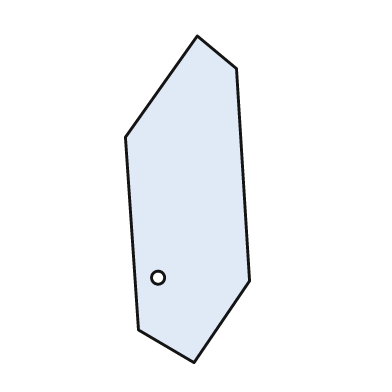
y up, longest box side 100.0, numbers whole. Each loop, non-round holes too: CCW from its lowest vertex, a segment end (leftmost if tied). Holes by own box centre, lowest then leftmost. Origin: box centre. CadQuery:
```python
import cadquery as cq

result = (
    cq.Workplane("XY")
    .moveTo(2.0, -50.0)
    .lineTo(19.0, -25.0)
    .lineTo(15.0, 40.0)
    .lineTo(3.0, 50.0)
    .lineTo(-19.0, 19.0)
    .lineTo(-15.0, -40.0)
    .close()
    .moveTo(-9.0, -24.0)
    .circle(2.0)
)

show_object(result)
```